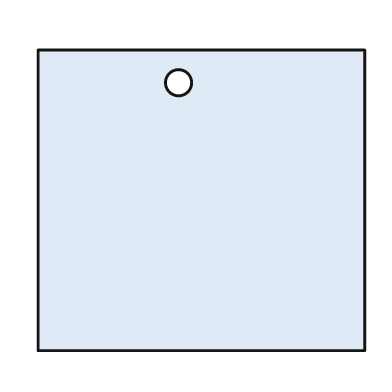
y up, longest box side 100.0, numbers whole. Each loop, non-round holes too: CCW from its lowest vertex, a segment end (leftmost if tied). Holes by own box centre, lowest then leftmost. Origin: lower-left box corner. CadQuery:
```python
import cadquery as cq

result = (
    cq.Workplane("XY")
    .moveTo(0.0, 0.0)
    .lineTo(100.0, 0.0)
    .lineTo(100.0, 92.0)
    .lineTo(0.0, 92.0)
    .close()
    .moveTo(43.0, 82.0)
    .circle(4.0)
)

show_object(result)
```